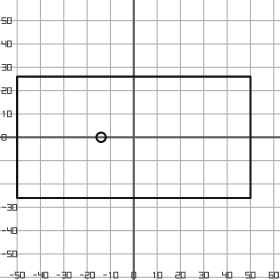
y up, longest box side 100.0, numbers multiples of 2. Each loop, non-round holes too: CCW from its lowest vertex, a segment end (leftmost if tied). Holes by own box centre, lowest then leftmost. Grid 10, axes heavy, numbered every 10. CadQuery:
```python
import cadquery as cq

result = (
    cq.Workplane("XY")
    .moveTo(-50.0, -26.0)
    .lineTo(50.0, -26.0)
    .lineTo(50.0, 26.0)
    .lineTo(-50.0, 26.0)
    .close()
    .moveTo(-14.0, 0.0)
    .circle(2.0)
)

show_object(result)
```